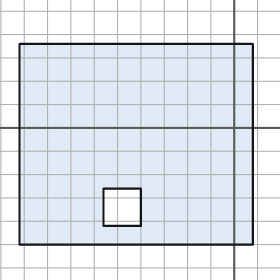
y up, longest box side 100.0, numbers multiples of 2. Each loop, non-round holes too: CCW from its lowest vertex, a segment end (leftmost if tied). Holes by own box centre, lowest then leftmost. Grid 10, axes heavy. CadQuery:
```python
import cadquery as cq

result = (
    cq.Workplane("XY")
    .moveTo(-92.0, -50.0)
    .lineTo(8.0, -50.0)
    .lineTo(8.0, 36.0)
    .lineTo(-92.0, 36.0)
    .close()
    .moveTo(-56.0, -42.0)
    .lineTo(-40.0, -42.0)
    .lineTo(-40.0, -26.0)
    .lineTo(-56.0, -26.0)
    .close()
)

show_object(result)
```